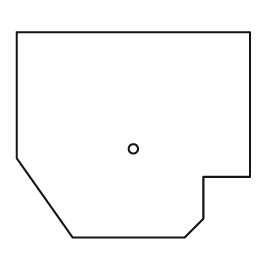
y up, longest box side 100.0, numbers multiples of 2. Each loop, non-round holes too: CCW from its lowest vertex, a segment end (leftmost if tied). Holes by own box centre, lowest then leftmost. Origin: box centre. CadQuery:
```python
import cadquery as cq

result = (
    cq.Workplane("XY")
    .moveTo(-26.0, -44.0)
    .lineTo(22.0, -44.0)
    .lineTo(30.0, -36.0)
    .lineTo(30.0, -18.0)
    .lineTo(50.0, -18.0)
    .lineTo(50.0, 44.0)
    .lineTo(-50.0, 44.0)
    .lineTo(-50.0, -10.0)
    .close()
    .moveTo(0.0, -6.0)
    .circle(2.0)
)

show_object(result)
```